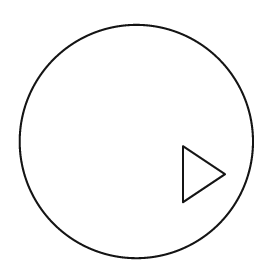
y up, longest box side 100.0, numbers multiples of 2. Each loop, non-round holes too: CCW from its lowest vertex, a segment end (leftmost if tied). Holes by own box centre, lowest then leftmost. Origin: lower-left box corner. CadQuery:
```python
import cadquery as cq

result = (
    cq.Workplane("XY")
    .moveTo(50.0, 50.0)
    .circle(50.0)
    .moveTo(70.0, 24.0)
    .lineTo(88.0, 36.0)
    .lineTo(70.0, 48.0)
    .close()
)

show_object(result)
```